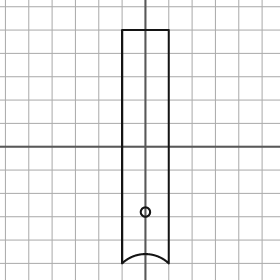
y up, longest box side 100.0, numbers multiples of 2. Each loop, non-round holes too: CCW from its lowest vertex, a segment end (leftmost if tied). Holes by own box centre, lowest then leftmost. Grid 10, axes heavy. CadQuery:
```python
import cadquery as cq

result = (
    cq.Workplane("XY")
    .moveTo(-10.0, -50.0)
    .threePointArc((0.0, -46.0), (10.0, -50.0))
    .lineTo(10.0, 50.0)
    .lineTo(-10.0, 50.0)
    .close()
    .moveTo(0.0, -28.0)
    .circle(2.0)
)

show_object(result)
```